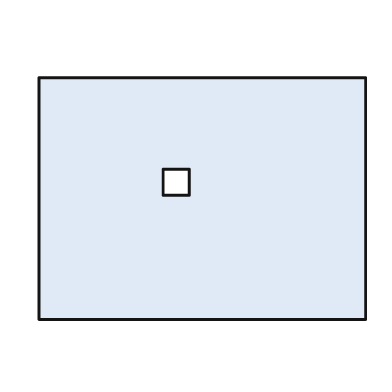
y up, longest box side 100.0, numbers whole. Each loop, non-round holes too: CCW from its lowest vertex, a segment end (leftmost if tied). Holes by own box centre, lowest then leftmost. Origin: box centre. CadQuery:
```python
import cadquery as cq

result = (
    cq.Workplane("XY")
    .moveTo(-50.0, -37.0)
    .lineTo(50.0, -37.0)
    .lineTo(50.0, 37.0)
    .lineTo(-50.0, 37.0)
    .close()
    .moveTo(-12.0, 1.0)
    .lineTo(-4.0, 1.0)
    .lineTo(-4.0, 9.0)
    .lineTo(-12.0, 9.0)
    .close()
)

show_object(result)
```